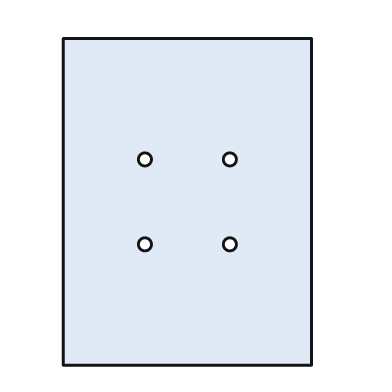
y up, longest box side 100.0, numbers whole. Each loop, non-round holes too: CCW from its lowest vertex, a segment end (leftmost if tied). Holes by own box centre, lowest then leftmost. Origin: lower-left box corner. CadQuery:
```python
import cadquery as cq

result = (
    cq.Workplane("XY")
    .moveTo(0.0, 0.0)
    .lineTo(76.0, 0.0)
    .lineTo(76.0, 100.0)
    .lineTo(0.0, 100.0)
    .close()
    .moveTo(25.0, 37.0)
    .circle(2.0)
    .moveTo(51.0, 37.0)
    .circle(2.0)
    .moveTo(25.0, 63.0)
    .circle(2.0)
    .moveTo(51.0, 63.0)
    .circle(2.0)
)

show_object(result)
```